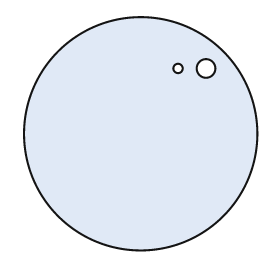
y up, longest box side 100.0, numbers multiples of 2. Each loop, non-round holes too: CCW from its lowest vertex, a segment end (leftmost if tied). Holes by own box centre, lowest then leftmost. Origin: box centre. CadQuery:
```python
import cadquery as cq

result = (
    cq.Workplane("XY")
    .moveTo(0.0, 0.0)
    .circle(50.0)
    .moveTo(16.0, 28.0)
    .circle(2.0)
    .moveTo(28.0, 28.0)
    .circle(4.0)
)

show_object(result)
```